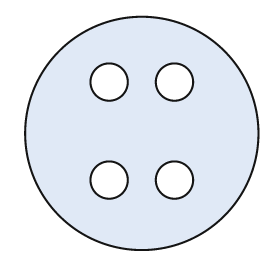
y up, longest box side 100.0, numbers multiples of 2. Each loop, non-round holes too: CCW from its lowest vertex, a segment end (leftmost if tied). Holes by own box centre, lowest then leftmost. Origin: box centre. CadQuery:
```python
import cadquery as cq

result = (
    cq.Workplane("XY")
    .moveTo(0.0, 0.0)
    .circle(50.0)
    .moveTo(-14.0, -20.0)
    .circle(8.0)
    .moveTo(14.0, -20.0)
    .circle(8.0)
    .moveTo(-14.0, 22.0)
    .circle(8.0)
    .moveTo(14.0, 22.0)
    .circle(8.0)
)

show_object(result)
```